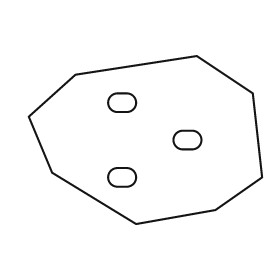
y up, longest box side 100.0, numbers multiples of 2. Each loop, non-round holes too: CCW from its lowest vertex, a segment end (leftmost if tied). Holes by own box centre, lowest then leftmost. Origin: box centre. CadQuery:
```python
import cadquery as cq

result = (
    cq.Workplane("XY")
    .moveTo(-4.0, -36.0)
    .lineTo(30.0, -30.0)
    .lineTo(50.0, -16.0)
    .lineTo(46.0, 20.0)
    .lineTo(22.0, 36.0)
    .lineTo(-30.0, 28.0)
    .lineTo(-50.0, 10.0)
    .lineTo(-40.0, -14.0)
    .close()
    .moveTo(-12.0, -20.0)
    .lineTo(-8.0, -20.0)
    .threePointArc((-4.0, -16.0), (-8.0, -12.0))
    .lineTo(-12.0, -12.0)
    .threePointArc((-16.0, -16.0), (-12.0, -20.0))
    .close()
    .moveTo(16.0, -4.0)
    .lineTo(20.0, -4.0)
    .threePointArc((24.0, 0.0), (20.0, 4.0))
    .lineTo(16.0, 4.0)
    .threePointArc((12.0, 0.0), (16.0, -4.0))
    .close()
    .moveTo(-12.0, 12.0)
    .lineTo(-8.0, 12.0)
    .threePointArc((-4.0, 16.0), (-8.0, 20.0))
    .lineTo(-12.0, 20.0)
    .threePointArc((-16.0, 16.0), (-12.0, 12.0))
    .close()
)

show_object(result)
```